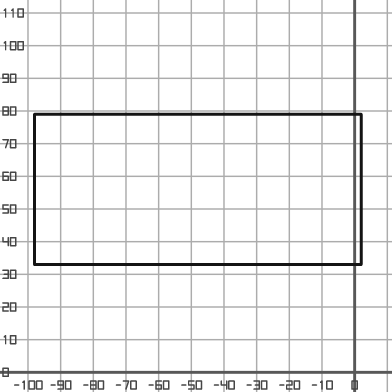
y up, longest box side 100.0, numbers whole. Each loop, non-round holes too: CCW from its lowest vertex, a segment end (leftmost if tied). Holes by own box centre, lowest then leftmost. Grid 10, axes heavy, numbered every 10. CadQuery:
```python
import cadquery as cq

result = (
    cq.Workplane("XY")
    .moveTo(-98.0, 33.0)
    .lineTo(2.0, 33.0)
    .lineTo(2.0, 79.0)
    .lineTo(-98.0, 79.0)
    .close()
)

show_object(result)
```